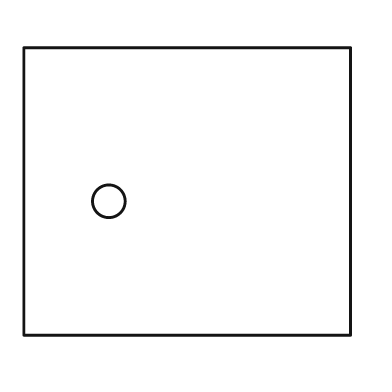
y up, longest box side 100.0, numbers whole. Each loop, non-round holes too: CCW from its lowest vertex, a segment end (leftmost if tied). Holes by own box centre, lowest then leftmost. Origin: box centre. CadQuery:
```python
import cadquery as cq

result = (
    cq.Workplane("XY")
    .moveTo(-50.0, -44.0)
    .lineTo(50.0, -44.0)
    .lineTo(50.0, 44.0)
    .lineTo(-50.0, 44.0)
    .close()
    .moveTo(-24.0, -3.0)
    .circle(5.0)
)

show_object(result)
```